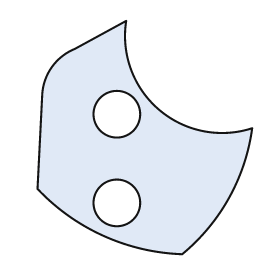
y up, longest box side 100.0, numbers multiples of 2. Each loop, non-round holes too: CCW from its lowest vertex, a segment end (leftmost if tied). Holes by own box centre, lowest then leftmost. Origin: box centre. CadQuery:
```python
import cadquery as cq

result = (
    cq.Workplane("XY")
    .moveTo(16.0, -50.0)
    .threePointArc((36.0, -26.0), (46.0, 4.0))
    .threePointArc((6.0, 12.0), (-8.0, 50.0))
    .lineTo(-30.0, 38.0)
    .threePointArc((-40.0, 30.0), (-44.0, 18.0))
    .lineTo(-46.0, -22.0)
    .threePointArc((-18.0, -42.0), (16.0, -50.0))
    .close()
    .moveTo(-12.0, -28.0)
    .circle(10.0)
    .moveTo(-12.0, 10.0)
    .circle(10.0)
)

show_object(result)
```